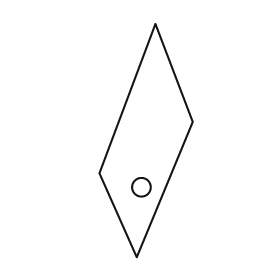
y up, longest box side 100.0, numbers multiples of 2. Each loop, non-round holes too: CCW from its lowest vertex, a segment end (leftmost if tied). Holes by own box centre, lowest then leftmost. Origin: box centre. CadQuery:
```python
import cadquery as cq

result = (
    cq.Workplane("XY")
    .moveTo(-4.0, -50.0)
    .lineTo(20.0, 8.0)
    .lineTo(4.0, 50.0)
    .lineTo(-20.0, -14.0)
    .close()
    .moveTo(-2.0, -20.0)
    .circle(4.0)
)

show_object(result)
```